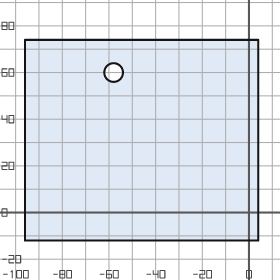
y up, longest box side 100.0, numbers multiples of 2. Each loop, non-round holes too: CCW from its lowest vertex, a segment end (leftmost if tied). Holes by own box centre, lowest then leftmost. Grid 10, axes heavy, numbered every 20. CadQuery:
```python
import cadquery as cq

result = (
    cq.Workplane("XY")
    .moveTo(-96.0, -12.0)
    .lineTo(4.0, -12.0)
    .lineTo(4.0, 74.0)
    .lineTo(-96.0, 74.0)
    .close()
    .moveTo(-58.0, 60.0)
    .circle(4.0)
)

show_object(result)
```